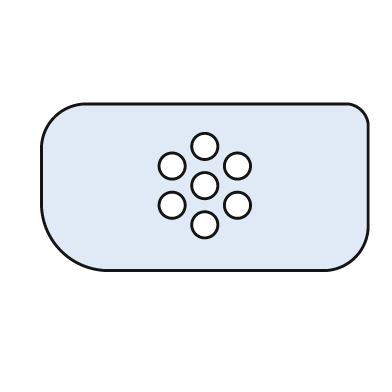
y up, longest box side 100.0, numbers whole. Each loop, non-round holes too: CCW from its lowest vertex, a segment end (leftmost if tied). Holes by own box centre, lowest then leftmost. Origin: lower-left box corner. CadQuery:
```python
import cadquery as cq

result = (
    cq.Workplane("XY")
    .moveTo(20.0, 0.0)
    .lineTo(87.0, 0.0)
    .threePointArc((96.0, 4.0), (100.0, 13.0))
    .lineTo(100.0, 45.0)
    .threePointArc((98.0, 49.0), (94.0, 51.0))
    .lineTo(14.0, 51.0)
    .threePointArc((4.0, 47.0), (0.0, 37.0))
    .lineTo(0.0, 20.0)
    .threePointArc((6.0, 6.0), (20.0, 0.0))
    .close()
    .moveTo(50.0, 14.0)
    .circle(4.0)
    .moveTo(40.0, 20.0)
    .circle(4.0)
    .moveTo(60.0, 20.0)
    .circle(4.0)
    .moveTo(50.0, 26.0)
    .circle(4.0)
    .moveTo(40.0, 32.0)
    .circle(4.0)
    .moveTo(60.0, 32.0)
    .circle(4.0)
    .moveTo(50.0, 38.0)
    .circle(4.0)
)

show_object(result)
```